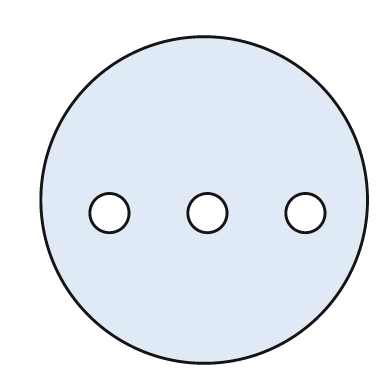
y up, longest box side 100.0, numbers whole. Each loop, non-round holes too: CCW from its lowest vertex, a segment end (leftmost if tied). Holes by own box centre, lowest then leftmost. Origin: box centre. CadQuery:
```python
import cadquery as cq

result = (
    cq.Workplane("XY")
    .moveTo(0.0, 0.0)
    .circle(50.0)
    .moveTo(-29.0, -4.0)
    .circle(6.0)
    .moveTo(1.0, -4.0)
    .circle(6.0)
    .moveTo(31.0, -4.0)
    .circle(6.0)
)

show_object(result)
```